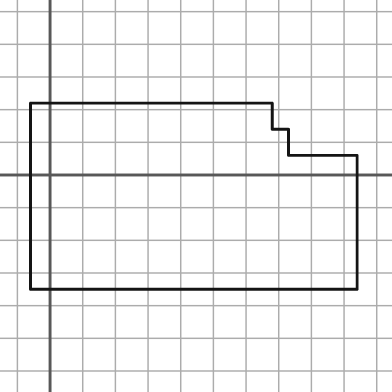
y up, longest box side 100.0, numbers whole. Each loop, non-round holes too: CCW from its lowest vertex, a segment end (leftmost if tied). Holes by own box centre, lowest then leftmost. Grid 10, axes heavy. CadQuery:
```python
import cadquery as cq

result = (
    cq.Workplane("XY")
    .moveTo(-6.0, -35.0)
    .lineTo(94.0, -35.0)
    .lineTo(94.0, 6.0)
    .lineTo(73.0, 6.0)
    .lineTo(73.0, 14.0)
    .lineTo(68.0, 14.0)
    .lineTo(68.0, 22.0)
    .lineTo(-6.0, 22.0)
    .close()
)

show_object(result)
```